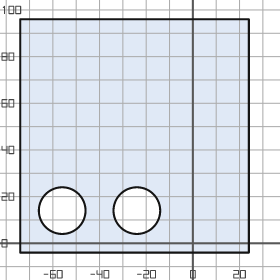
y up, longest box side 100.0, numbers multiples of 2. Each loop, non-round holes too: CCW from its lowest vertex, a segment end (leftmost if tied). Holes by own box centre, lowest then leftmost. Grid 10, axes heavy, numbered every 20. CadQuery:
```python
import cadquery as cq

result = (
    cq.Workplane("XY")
    .moveTo(-74.0, -4.0)
    .lineTo(24.0, -4.0)
    .lineTo(24.0, 96.0)
    .lineTo(-74.0, 96.0)
    .close()
    .moveTo(-56.0, 14.0)
    .circle(10.0)
    .moveTo(-24.0, 14.0)
    .circle(10.0)
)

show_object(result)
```